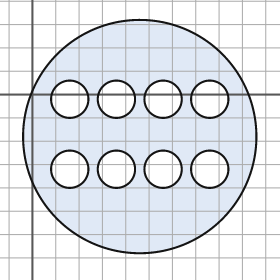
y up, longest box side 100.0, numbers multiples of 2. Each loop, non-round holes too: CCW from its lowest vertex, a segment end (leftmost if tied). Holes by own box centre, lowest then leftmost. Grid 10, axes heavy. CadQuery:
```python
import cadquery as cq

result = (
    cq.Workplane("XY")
    .moveTo(46.0, -18.0)
    .circle(50.0)
    .moveTo(16.0, -32.0)
    .circle(8.0)
    .moveTo(36.0, -32.0)
    .circle(8.0)
    .moveTo(56.0, -32.0)
    .circle(8.0)
    .moveTo(76.0, -32.0)
    .circle(8.0)
    .moveTo(16.0, -2.0)
    .circle(8.0)
    .moveTo(36.0, -2.0)
    .circle(8.0)
    .moveTo(56.0, -2.0)
    .circle(8.0)
    .moveTo(76.0, -2.0)
    .circle(8.0)
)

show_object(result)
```